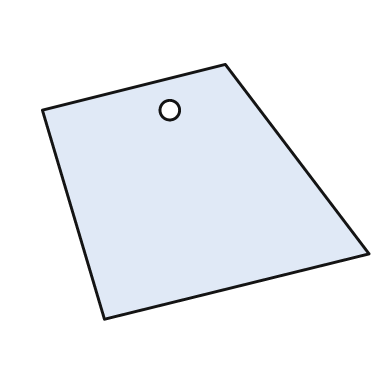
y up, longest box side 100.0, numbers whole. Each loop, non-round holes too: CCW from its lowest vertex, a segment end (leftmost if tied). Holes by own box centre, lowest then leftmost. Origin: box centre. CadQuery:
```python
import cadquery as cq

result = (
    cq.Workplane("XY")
    .moveTo(-31.0, -39.0)
    .lineTo(50.0, -19.0)
    .lineTo(6.0, 39.0)
    .lineTo(-50.0, 25.0)
    .close()
    .moveTo(-11.0, 25.0)
    .circle(3.0)
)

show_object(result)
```